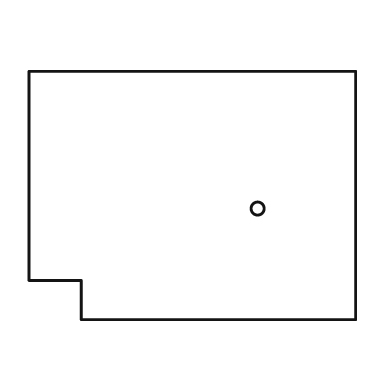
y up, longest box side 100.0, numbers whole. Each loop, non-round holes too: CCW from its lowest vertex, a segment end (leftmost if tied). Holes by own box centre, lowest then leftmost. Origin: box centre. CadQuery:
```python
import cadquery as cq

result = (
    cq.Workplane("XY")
    .moveTo(-34.0, -38.0)
    .lineTo(50.0, -38.0)
    .lineTo(50.0, 38.0)
    .lineTo(-50.0, 38.0)
    .lineTo(-50.0, -26.0)
    .lineTo(-34.0, -26.0)
    .close()
    .moveTo(20.0, -4.0)
    .circle(2.0)
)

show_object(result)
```